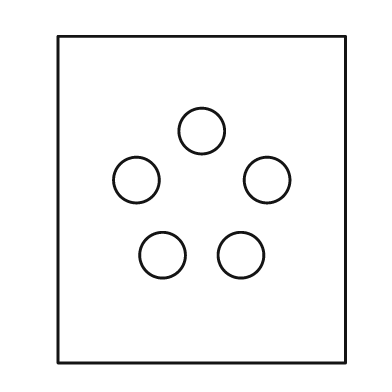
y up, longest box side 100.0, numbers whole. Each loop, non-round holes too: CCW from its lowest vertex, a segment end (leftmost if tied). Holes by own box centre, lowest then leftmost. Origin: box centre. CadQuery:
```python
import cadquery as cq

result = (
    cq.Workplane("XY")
    .moveTo(-44.0, -50.0)
    .lineTo(44.0, -50.0)
    .lineTo(44.0, 50.0)
    .lineTo(-44.0, 50.0)
    .close()
    .moveTo(-12.0, -17.0)
    .circle(7.0)
    .moveTo(12.0, -17.0)
    .circle(7.0)
    .moveTo(-20.0, 6.0)
    .circle(7.0)
    .moveTo(20.0, 6.0)
    .circle(7.0)
    .moveTo(0.0, 21.0)
    .circle(7.0)
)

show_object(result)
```